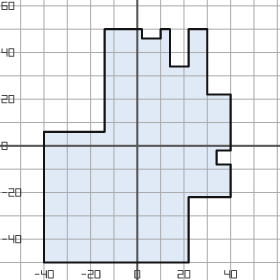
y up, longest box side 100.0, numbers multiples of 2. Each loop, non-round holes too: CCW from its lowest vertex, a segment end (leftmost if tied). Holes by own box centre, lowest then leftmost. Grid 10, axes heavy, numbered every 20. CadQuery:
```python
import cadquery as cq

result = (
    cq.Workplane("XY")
    .moveTo(-40.0, -50.0)
    .lineTo(22.0, -50.0)
    .lineTo(22.0, -22.0)
    .lineTo(40.0, -22.0)
    .lineTo(40.0, -8.0)
    .lineTo(34.0, -8.0)
    .lineTo(34.0, -2.0)
    .lineTo(40.0, -2.0)
    .lineTo(40.0, 22.0)
    .lineTo(30.0, 22.0)
    .lineTo(30.0, 50.0)
    .lineTo(22.0, 50.0)
    .lineTo(22.0, 34.0)
    .lineTo(14.0, 34.0)
    .lineTo(14.0, 50.0)
    .lineTo(10.0, 50.0)
    .lineTo(10.0, 46.0)
    .lineTo(2.0, 46.0)
    .lineTo(2.0, 50.0)
    .lineTo(-14.0, 50.0)
    .lineTo(-14.0, 6.0)
    .lineTo(-40.0, 6.0)
    .close()
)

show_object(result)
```